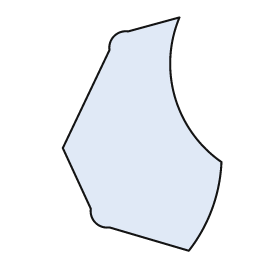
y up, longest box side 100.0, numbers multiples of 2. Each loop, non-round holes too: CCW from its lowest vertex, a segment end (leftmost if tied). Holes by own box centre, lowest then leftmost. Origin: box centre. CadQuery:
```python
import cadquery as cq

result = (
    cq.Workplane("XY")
    .moveTo(20.0, -50.0)
    .threePointArc((30.0, -32.0), (34.0, -12.0))
    .threePointArc((14.0, 16.0), (16.0, 50.0))
    .lineTo(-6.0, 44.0)
    .threePointArc((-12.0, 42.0), (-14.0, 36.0))
    .lineTo(-34.0, -6.0)
    .lineTo(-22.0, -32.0)
    .threePointArc((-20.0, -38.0), (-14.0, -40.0))
    .close()
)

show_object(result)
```